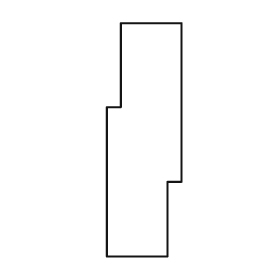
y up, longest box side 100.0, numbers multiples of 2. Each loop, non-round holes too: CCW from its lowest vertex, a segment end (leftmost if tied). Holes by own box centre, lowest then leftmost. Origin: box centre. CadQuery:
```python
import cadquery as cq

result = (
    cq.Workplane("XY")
    .moveTo(-16.0, -50.0)
    .lineTo(10.0, -50.0)
    .lineTo(10.0, -18.0)
    .lineTo(16.0, -18.0)
    .lineTo(16.0, 50.0)
    .lineTo(-10.0, 50.0)
    .lineTo(-10.0, 14.0)
    .lineTo(-16.0, 14.0)
    .close()
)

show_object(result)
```